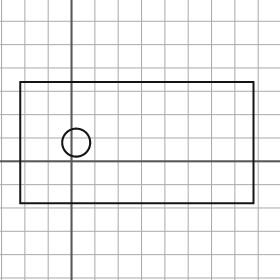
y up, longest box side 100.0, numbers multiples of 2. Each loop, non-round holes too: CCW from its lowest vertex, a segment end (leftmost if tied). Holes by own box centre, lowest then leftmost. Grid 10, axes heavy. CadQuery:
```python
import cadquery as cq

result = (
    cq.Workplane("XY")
    .moveTo(-22.0, -18.0)
    .lineTo(78.0, -18.0)
    .lineTo(78.0, 34.0)
    .lineTo(-22.0, 34.0)
    .close()
    .moveTo(2.0, 8.0)
    .circle(6.0)
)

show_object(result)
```